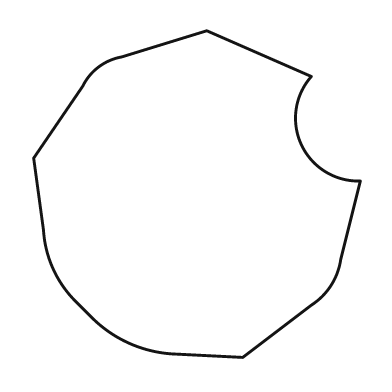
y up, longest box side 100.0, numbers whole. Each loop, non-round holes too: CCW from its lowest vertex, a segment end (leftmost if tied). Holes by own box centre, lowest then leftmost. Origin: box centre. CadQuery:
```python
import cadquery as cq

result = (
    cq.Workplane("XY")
    .moveTo(14.0, -50.0)
    .lineTo(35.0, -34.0)
    .threePointArc((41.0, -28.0), (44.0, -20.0))
    .lineTo(50.0, 4.0)
    .threePointArc((32.0, 15.0), (35.0, 36.0))
    .lineTo(3.0, 50.0)
    .lineTo(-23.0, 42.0)
    .threePointArc((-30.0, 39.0), (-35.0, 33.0))
    .lineTo(-50.0, 11.0)
    .lineTo(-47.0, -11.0)
    .threePointArc((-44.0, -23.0), (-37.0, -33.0))
    .lineTo(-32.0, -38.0)
    .threePointArc((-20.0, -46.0), (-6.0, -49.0))
    .close()
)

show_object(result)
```